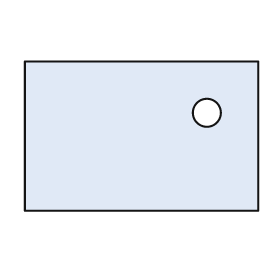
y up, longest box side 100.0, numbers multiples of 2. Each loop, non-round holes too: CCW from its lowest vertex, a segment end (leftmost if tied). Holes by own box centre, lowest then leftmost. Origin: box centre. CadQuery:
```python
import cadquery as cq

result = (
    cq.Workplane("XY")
    .moveTo(-50.0, -32.0)
    .lineTo(50.0, -32.0)
    .lineTo(50.0, 32.0)
    .lineTo(-50.0, 32.0)
    .close()
    .moveTo(28.0, 10.0)
    .circle(6.0)
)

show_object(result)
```